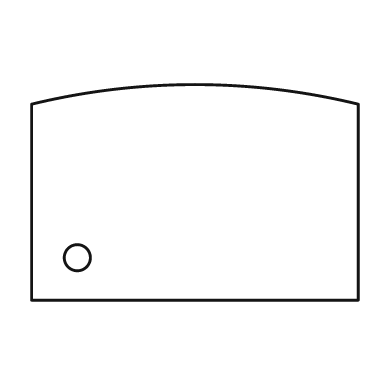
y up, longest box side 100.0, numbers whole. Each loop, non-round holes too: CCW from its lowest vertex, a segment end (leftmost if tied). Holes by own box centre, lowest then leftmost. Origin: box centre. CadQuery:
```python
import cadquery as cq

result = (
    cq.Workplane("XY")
    .moveTo(-50.0, -33.0)
    .lineTo(50.0, -33.0)
    .lineTo(50.0, 27.0)
    .threePointArc((0.0, 33.0), (-50.0, 27.0))
    .close()
    .moveTo(-36.0, -20.0)
    .circle(4.0)
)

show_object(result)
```